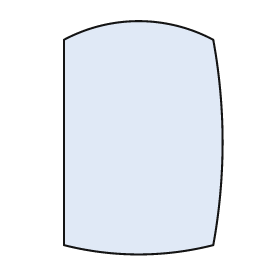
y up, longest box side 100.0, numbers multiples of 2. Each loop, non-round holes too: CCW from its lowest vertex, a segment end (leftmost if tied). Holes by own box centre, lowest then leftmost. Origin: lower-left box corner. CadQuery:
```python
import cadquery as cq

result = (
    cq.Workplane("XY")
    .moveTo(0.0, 4.0)
    .threePointArc((32.0, 0.0), (64.0, 4.0))
    .threePointArc((68.0, 48.0), (64.0, 92.0))
    .threePointArc((32.0, 100.0), (0.0, 92.0))
    .close()
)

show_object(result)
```